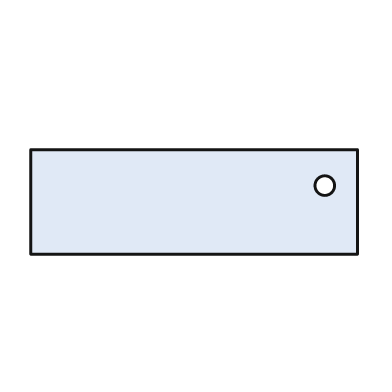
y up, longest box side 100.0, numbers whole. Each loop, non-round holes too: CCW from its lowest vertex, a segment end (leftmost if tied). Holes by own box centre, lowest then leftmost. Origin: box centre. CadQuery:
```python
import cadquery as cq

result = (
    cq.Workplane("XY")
    .moveTo(-50.0, -16.0)
    .lineTo(50.0, -16.0)
    .lineTo(50.0, 16.0)
    .lineTo(-50.0, 16.0)
    .close()
    .moveTo(40.0, 5.0)
    .circle(3.0)
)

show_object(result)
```